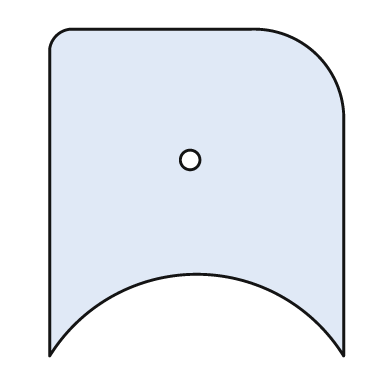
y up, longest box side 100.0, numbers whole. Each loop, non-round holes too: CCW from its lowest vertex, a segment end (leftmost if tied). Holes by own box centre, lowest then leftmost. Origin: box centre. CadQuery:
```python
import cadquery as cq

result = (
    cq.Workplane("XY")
    .moveTo(-45.0, -50.0)
    .threePointArc((0.0, -25.0), (45.0, -50.0))
    .lineTo(45.0, 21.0)
    .threePointArc((37.0, 42.0), (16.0, 50.0))
    .lineTo(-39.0, 50.0)
    .threePointArc((-43.0, 48.0), (-45.0, 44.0))
    .close()
    .moveTo(-2.0, 10.0)
    .circle(3.0)
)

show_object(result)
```